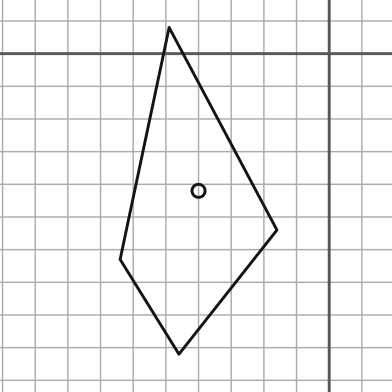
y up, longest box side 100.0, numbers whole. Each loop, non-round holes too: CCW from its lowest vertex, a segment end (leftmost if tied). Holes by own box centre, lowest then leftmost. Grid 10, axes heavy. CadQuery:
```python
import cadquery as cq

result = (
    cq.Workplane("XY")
    .moveTo(-46.0, -92.0)
    .lineTo(-16.0, -54.0)
    .lineTo(-49.0, 8.0)
    .lineTo(-64.0, -63.0)
    .close()
    .moveTo(-40.0, -42.0)
    .circle(2.0)
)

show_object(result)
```